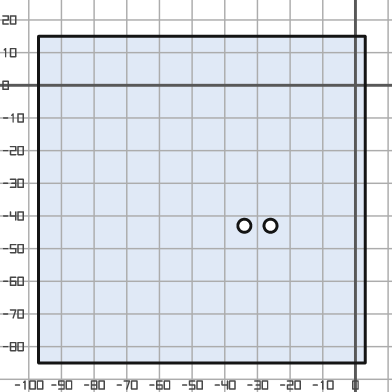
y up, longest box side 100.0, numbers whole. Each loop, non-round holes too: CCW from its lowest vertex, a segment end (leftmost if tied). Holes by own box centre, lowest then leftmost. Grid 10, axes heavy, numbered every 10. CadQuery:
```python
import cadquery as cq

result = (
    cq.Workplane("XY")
    .moveTo(-97.0, -85.0)
    .lineTo(3.0, -85.0)
    .lineTo(3.0, 15.0)
    .lineTo(-97.0, 15.0)
    .close()
    .moveTo(-34.0, -43.0)
    .circle(2.0)
    .moveTo(-26.0, -43.0)
    .circle(2.0)
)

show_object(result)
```